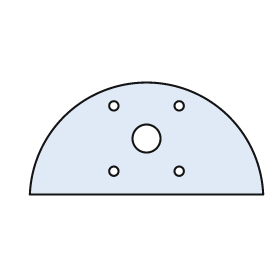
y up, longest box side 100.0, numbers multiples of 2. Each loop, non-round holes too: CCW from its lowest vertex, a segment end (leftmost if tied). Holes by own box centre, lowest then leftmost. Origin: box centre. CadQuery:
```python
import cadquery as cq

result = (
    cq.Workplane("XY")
    .moveTo(-50.0, -24.0)
    .lineTo(50.0, -24.0)
    .threePointArc((0.0, 24.0), (-50.0, -24.0))
    .close()
    .moveTo(-14.0, -14.0)
    .circle(2.0)
    .moveTo(14.0, -14.0)
    .circle(2.0)
    .moveTo(0.0, 0.0)
    .circle(6.0)
    .moveTo(-14.0, 14.0)
    .circle(2.0)
    .moveTo(14.0, 14.0)
    .circle(2.0)
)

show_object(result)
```